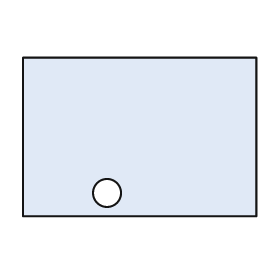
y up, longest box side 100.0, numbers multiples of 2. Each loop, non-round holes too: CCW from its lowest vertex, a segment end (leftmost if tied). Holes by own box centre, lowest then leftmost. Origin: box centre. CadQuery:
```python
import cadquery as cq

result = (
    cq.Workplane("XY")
    .moveTo(-50.0, -34.0)
    .lineTo(50.0, -34.0)
    .lineTo(50.0, 34.0)
    .lineTo(-50.0, 34.0)
    .close()
    .moveTo(-14.0, -24.0)
    .circle(6.0)
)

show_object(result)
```